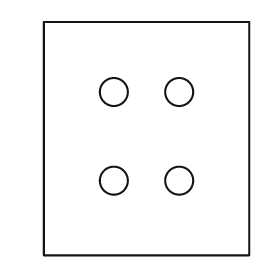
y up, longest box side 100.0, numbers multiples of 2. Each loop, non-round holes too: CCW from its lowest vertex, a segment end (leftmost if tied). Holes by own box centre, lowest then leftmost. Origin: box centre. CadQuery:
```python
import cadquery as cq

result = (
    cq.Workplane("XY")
    .moveTo(-44.0, -50.0)
    .lineTo(44.0, -50.0)
    .lineTo(44.0, 50.0)
    .lineTo(-44.0, 50.0)
    .close()
    .moveTo(-14.0, -18.0)
    .circle(6.0)
    .moveTo(14.0, -18.0)
    .circle(6.0)
    .moveTo(-14.0, 20.0)
    .circle(6.0)
    .moveTo(14.0, 20.0)
    .circle(6.0)
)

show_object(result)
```